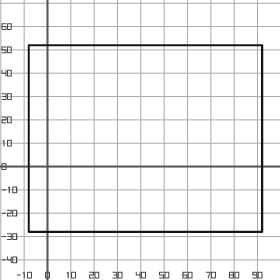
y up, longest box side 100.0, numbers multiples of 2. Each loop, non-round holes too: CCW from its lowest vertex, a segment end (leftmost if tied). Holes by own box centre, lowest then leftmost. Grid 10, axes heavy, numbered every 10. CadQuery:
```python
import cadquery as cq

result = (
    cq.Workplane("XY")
    .moveTo(-8.0, -28.0)
    .lineTo(92.0, -28.0)
    .lineTo(92.0, 52.0)
    .lineTo(-8.0, 52.0)
    .close()
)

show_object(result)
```